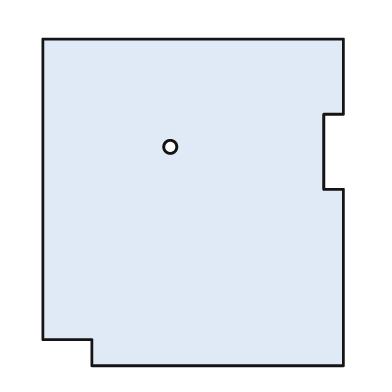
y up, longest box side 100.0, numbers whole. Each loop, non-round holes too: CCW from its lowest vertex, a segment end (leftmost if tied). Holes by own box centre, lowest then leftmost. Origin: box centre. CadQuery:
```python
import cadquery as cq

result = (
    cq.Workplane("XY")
    .moveTo(-31.0, -50.0)
    .lineTo(46.0, -50.0)
    .lineTo(46.0, 4.0)
    .lineTo(40.0, 4.0)
    .lineTo(40.0, 27.0)
    .lineTo(46.0, 27.0)
    .lineTo(46.0, 50.0)
    .lineTo(-46.0, 50.0)
    .lineTo(-46.0, -42.0)
    .lineTo(-31.0, -42.0)
    .close()
    .moveTo(-7.0, 17.0)
    .circle(2.0)
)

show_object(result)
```